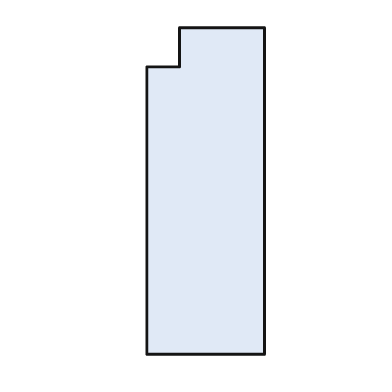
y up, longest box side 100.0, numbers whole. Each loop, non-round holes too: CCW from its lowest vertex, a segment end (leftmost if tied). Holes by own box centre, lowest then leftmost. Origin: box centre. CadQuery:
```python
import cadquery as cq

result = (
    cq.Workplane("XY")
    .moveTo(-18.0, -50.0)
    .lineTo(18.0, -50.0)
    .lineTo(18.0, 50.0)
    .lineTo(-8.0, 50.0)
    .lineTo(-8.0, 38.0)
    .lineTo(-18.0, 38.0)
    .close()
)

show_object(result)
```